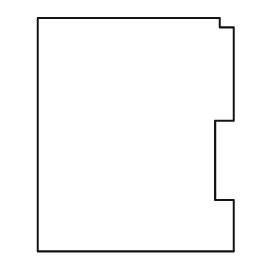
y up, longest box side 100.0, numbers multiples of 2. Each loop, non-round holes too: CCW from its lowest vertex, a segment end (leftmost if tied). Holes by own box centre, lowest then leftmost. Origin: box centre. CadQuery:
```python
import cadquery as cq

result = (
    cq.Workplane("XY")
    .moveTo(-42.0, -50.0)
    .lineTo(42.0, -50.0)
    .lineTo(42.0, -28.0)
    .lineTo(34.0, -28.0)
    .lineTo(34.0, 6.0)
    .lineTo(42.0, 6.0)
    .lineTo(42.0, 46.0)
    .lineTo(36.0, 46.0)
    .lineTo(36.0, 50.0)
    .lineTo(-42.0, 50.0)
    .close()
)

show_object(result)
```